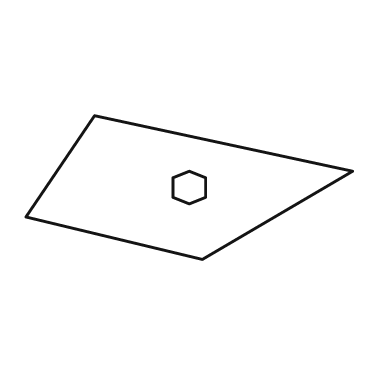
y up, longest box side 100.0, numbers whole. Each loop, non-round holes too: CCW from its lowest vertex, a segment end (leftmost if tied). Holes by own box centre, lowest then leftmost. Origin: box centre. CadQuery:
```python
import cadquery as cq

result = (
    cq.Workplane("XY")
    .moveTo(4.0, -22.0)
    .lineTo(50.0, 5.0)
    .lineTo(-29.0, 22.0)
    .lineTo(-50.0, -9.0)
    .close()
    .moveTo(0.0, -5.0)
    .lineTo(5.0, -3.0)
    .lineTo(5.0, 3.0)
    .lineTo(0.0, 5.0)
    .lineTo(-5.0, 3.0)
    .lineTo(-5.0, -3.0)
    .close()
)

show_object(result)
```